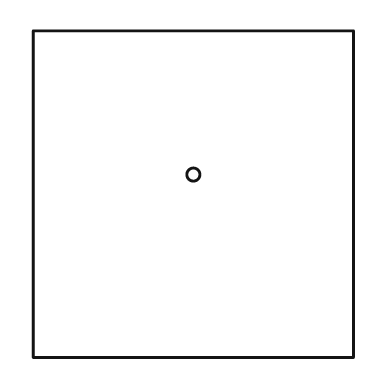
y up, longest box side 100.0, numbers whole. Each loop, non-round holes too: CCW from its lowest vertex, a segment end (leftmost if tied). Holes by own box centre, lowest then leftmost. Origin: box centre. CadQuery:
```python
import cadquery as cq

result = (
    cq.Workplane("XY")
    .moveTo(-49.0, -50.0)
    .lineTo(49.0, -50.0)
    .lineTo(49.0, 50.0)
    .lineTo(-49.0, 50.0)
    .close()
    .moveTo(0.0, 6.0)
    .circle(2.0)
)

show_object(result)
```